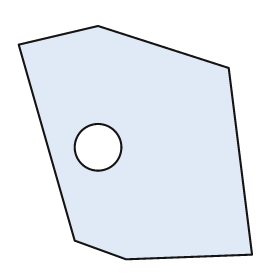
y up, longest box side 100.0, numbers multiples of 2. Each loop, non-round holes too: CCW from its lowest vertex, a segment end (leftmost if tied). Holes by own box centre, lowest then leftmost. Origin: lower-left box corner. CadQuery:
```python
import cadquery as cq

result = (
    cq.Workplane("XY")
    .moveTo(46.0, 0.0)
    .lineTo(100.0, 2.0)
    .lineTo(90.0, 82.0)
    .lineTo(34.0, 100.0)
    .lineTo(0.0, 92.0)
    .lineTo(24.0, 8.0)
    .close()
    .moveTo(34.0, 48.0)
    .circle(10.0)
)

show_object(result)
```